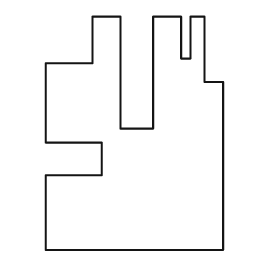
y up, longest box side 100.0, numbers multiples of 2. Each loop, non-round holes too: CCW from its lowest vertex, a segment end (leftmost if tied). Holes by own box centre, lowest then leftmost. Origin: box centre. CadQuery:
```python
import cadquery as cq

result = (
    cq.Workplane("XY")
    .moveTo(-38.0, -50.0)
    .lineTo(38.0, -50.0)
    .lineTo(38.0, 22.0)
    .lineTo(30.0, 22.0)
    .lineTo(30.0, 50.0)
    .lineTo(24.0, 50.0)
    .lineTo(24.0, 32.0)
    .lineTo(20.0, 32.0)
    .lineTo(20.0, 50.0)
    .lineTo(8.0, 50.0)
    .lineTo(8.0, 2.0)
    .lineTo(-6.0, 2.0)
    .lineTo(-6.0, 50.0)
    .lineTo(-18.0, 50.0)
    .lineTo(-18.0, 30.0)
    .lineTo(-38.0, 30.0)
    .lineTo(-38.0, -4.0)
    .lineTo(-14.0, -4.0)
    .lineTo(-14.0, -18.0)
    .lineTo(-38.0, -18.0)
    .close()
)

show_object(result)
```